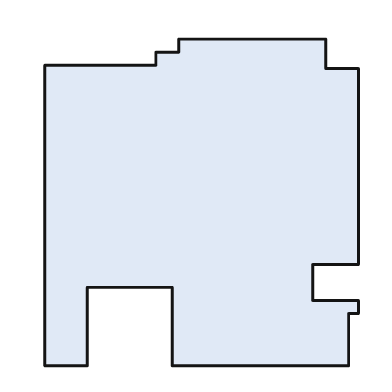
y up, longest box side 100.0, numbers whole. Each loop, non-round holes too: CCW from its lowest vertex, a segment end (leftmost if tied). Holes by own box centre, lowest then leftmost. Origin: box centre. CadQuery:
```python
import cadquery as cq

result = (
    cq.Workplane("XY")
    .moveTo(-48.0, -50.0)
    .lineTo(-35.0, -50.0)
    .lineTo(-35.0, -26.0)
    .lineTo(-9.0, -26.0)
    .lineTo(-9.0, -50.0)
    .lineTo(45.0, -50.0)
    .lineTo(45.0, -34.0)
    .lineTo(48.0, -34.0)
    .lineTo(48.0, -30.0)
    .lineTo(34.0, -30.0)
    .lineTo(34.0, -19.0)
    .lineTo(48.0, -19.0)
    .lineTo(48.0, 41.0)
    .lineTo(38.0, 41.0)
    .lineTo(38.0, 50.0)
    .lineTo(-7.0, 50.0)
    .lineTo(-7.0, 46.0)
    .lineTo(-14.0, 46.0)
    .lineTo(-14.0, 42.0)
    .lineTo(-48.0, 42.0)
    .close()
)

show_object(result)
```